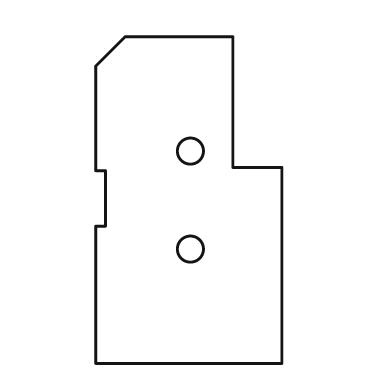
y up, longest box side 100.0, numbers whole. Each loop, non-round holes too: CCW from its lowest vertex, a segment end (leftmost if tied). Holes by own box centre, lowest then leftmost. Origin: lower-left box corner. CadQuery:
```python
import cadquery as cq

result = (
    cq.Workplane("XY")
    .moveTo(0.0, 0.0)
    .lineTo(57.0, 0.0)
    .lineTo(57.0, 60.0)
    .lineTo(42.0, 60.0)
    .lineTo(42.0, 100.0)
    .lineTo(9.0, 100.0)
    .lineTo(0.0, 91.0)
    .lineTo(0.0, 59.0)
    .lineTo(3.0, 59.0)
    .lineTo(3.0, 42.0)
    .lineTo(0.0, 42.0)
    .close()
    .moveTo(29.0, 35.0)
    .circle(4.0)
    .moveTo(29.0, 65.0)
    .circle(4.0)
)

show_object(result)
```